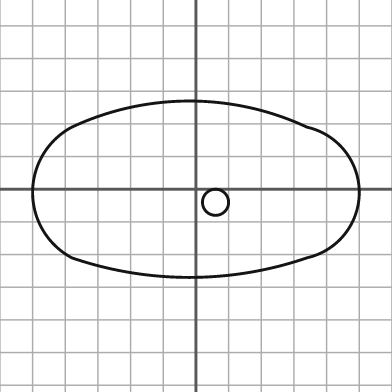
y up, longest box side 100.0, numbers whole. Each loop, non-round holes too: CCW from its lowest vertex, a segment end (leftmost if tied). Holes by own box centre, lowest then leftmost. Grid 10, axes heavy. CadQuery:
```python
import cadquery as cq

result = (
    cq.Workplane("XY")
    .moveTo(-38.0, -21.0)
    .threePointArc((-2.0, -27.0), (34.0, -21.0))
    .threePointArc((50.0, -1.0), (34.0, 19.0))
    .threePointArc((-2.0, 27.0), (-38.0, 19.0))
    .threePointArc((-50.0, -1.0), (-38.0, -21.0))
    .close()
    .moveTo(6.0, -4.0)
    .circle(4.0)
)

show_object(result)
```